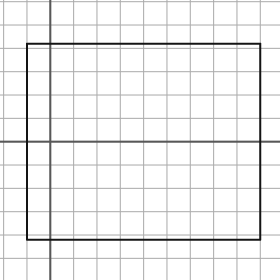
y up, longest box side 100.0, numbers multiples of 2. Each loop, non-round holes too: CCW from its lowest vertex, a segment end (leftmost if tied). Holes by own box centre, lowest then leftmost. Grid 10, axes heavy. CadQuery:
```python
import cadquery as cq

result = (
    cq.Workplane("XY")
    .moveTo(-10.0, -42.0)
    .lineTo(90.0, -42.0)
    .lineTo(90.0, 42.0)
    .lineTo(-10.0, 42.0)
    .close()
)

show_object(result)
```